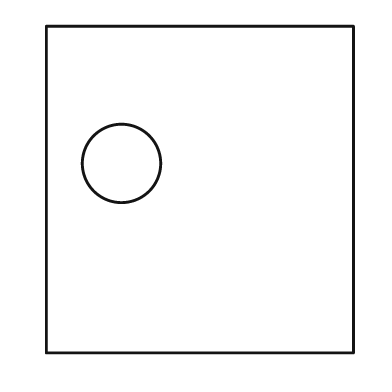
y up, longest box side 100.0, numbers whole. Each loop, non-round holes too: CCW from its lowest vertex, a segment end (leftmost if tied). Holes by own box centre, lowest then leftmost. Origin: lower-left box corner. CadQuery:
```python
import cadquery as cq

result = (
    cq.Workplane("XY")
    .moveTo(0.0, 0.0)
    .lineTo(94.0, 0.0)
    .lineTo(94.0, 100.0)
    .lineTo(0.0, 100.0)
    .close()
    .moveTo(23.0, 58.0)
    .circle(12.0)
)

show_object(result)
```